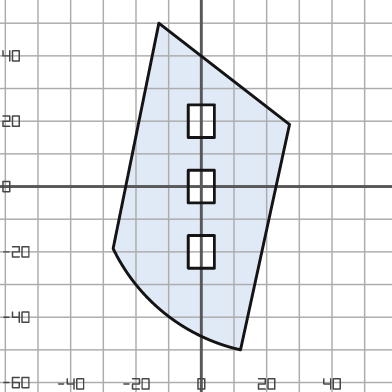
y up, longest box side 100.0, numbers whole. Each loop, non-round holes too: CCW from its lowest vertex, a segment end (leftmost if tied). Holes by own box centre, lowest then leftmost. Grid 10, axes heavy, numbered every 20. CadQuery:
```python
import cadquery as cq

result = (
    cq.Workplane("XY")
    .moveTo(12.0, -50.0)
    .lineTo(27.0, 19.0)
    .lineTo(-13.0, 50.0)
    .lineTo(-27.0, -19.0)
    .threePointArc((-11.0, -39.0), (12.0, -50.0))
    .close()
    .moveTo(-4.0, -25.0)
    .lineTo(4.0, -25.0)
    .lineTo(4.0, -15.0)
    .lineTo(-4.0, -15.0)
    .close()
    .moveTo(-4.0, -5.0)
    .lineTo(4.0, -5.0)
    .lineTo(4.0, 5.0)
    .lineTo(-4.0, 5.0)
    .close()
    .moveTo(-4.0, 15.0)
    .lineTo(4.0, 15.0)
    .lineTo(4.0, 25.0)
    .lineTo(-4.0, 25.0)
    .close()
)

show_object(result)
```